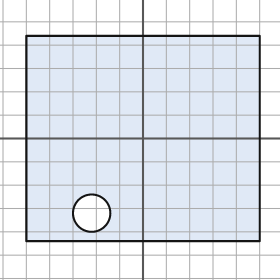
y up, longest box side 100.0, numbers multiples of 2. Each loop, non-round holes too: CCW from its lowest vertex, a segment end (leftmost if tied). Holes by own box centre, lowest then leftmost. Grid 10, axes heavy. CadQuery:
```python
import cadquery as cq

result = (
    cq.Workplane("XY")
    .moveTo(-50.0, -44.0)
    .lineTo(50.0, -44.0)
    .lineTo(50.0, 44.0)
    .lineTo(-50.0, 44.0)
    .close()
    .moveTo(-22.0, -32.0)
    .circle(8.0)
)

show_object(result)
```